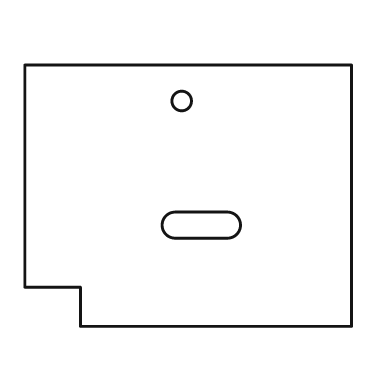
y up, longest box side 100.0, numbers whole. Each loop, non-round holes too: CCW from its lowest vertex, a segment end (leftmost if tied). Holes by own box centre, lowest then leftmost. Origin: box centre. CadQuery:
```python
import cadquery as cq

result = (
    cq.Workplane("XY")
    .moveTo(-33.0, -40.0)
    .lineTo(50.0, -40.0)
    .lineTo(50.0, 40.0)
    .lineTo(-50.0, 40.0)
    .lineTo(-50.0, -28.0)
    .lineTo(-33.0, -28.0)
    .close()
    .moveTo(-4.0, -13.0)
    .lineTo(12.0, -13.0)
    .threePointArc((16.0, -9.0), (12.0, -5.0))
    .lineTo(-4.0, -5.0)
    .threePointArc((-8.0, -9.0), (-4.0, -13.0))
    .close()
    .moveTo(-2.0, 29.0)
    .circle(3.0)
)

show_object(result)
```